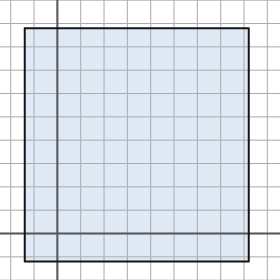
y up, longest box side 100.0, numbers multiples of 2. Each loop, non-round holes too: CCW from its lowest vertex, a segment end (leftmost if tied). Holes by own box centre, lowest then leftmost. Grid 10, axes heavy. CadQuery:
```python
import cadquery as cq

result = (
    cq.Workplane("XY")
    .moveTo(-14.0, -12.0)
    .lineTo(82.0, -12.0)
    .lineTo(82.0, 88.0)
    .lineTo(-14.0, 88.0)
    .close()
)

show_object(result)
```